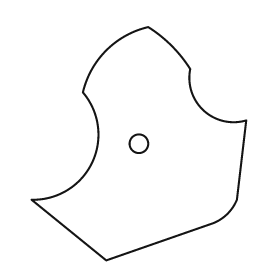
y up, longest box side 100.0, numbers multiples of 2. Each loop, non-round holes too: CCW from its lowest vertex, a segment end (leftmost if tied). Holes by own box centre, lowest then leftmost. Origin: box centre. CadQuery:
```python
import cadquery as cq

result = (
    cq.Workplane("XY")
    .moveTo(-14.0, -50.0)
    .lineTo(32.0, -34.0)
    .threePointArc((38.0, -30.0), (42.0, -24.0))
    .lineTo(46.0, 10.0)
    .threePointArc((28.0, 14.0), (22.0, 32.0))
    .threePointArc((14.0, 42.0), (4.0, 50.0))
    .threePointArc((-14.0, 40.0), (-24.0, 22.0))
    .threePointArc((-20.0, -8.0), (-46.0, -24.0))
    .close()
    .moveTo(0.0, 0.0)
    .circle(4.0)
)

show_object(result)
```